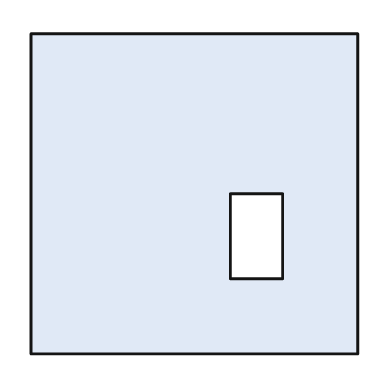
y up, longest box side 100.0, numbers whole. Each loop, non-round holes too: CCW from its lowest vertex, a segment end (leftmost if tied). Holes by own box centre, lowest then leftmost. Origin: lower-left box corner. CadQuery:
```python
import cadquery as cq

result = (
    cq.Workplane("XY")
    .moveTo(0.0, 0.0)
    .lineTo(100.0, 0.0)
    .lineTo(100.0, 98.0)
    .lineTo(0.0, 98.0)
    .close()
    .moveTo(61.0, 23.0)
    .lineTo(77.0, 23.0)
    .lineTo(77.0, 49.0)
    .lineTo(61.0, 49.0)
    .close()
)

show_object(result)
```